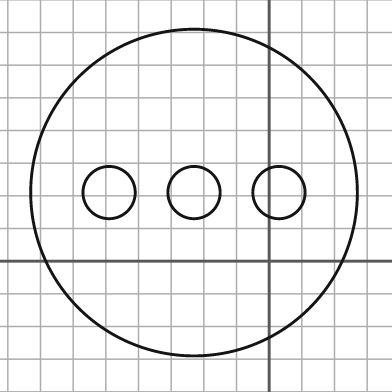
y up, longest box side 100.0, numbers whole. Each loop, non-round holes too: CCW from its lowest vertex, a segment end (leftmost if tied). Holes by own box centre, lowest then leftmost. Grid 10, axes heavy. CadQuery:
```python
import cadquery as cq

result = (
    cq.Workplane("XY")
    .moveTo(-23.0, 21.0)
    .circle(50.0)
    .moveTo(-49.0, 21.0)
    .circle(8.0)
    .moveTo(-23.0, 21.0)
    .circle(8.0)
    .moveTo(3.0, 21.0)
    .circle(8.0)
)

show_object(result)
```